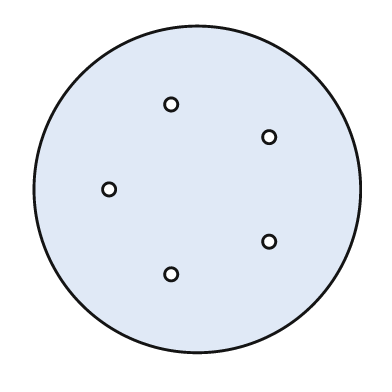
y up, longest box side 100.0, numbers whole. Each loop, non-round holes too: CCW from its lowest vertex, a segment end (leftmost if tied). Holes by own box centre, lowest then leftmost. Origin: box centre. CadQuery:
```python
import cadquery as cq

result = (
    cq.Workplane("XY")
    .moveTo(0.0, 0.0)
    .circle(50.0)
    .moveTo(-8.0, -26.0)
    .circle(2.0)
    .moveTo(22.0, -16.0)
    .circle(2.0)
    .moveTo(-27.0, 0.0)
    .circle(2.0)
    .moveTo(22.0, 16.0)
    .circle(2.0)
    .moveTo(-8.0, 26.0)
    .circle(2.0)
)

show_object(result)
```